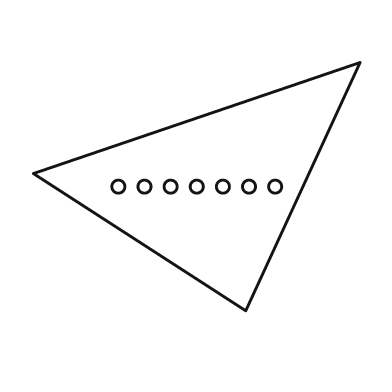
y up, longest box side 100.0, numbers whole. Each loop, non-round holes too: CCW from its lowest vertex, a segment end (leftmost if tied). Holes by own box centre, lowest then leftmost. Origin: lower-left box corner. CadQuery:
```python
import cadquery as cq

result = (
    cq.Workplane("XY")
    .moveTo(65.0, 0.0)
    .lineTo(100.0, 76.0)
    .lineTo(0.0, 42.0)
    .close()
    .moveTo(26.0, 38.0)
    .circle(2.0)
    .moveTo(34.0, 38.0)
    .circle(2.0)
    .moveTo(42.0, 38.0)
    .circle(2.0)
    .moveTo(50.0, 38.0)
    .circle(2.0)
    .moveTo(58.0, 38.0)
    .circle(2.0)
    .moveTo(66.0, 38.0)
    .circle(2.0)
    .moveTo(74.0, 38.0)
    .circle(2.0)
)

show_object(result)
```